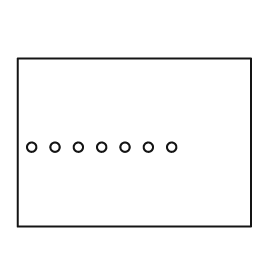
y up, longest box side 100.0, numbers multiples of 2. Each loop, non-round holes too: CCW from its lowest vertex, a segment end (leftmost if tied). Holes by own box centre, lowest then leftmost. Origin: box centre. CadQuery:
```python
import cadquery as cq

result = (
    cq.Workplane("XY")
    .moveTo(-50.0, -36.0)
    .lineTo(50.0, -36.0)
    .lineTo(50.0, 36.0)
    .lineTo(-50.0, 36.0)
    .close()
    .moveTo(-44.0, -2.0)
    .circle(2.0)
    .moveTo(-34.0, -2.0)
    .circle(2.0)
    .moveTo(-24.0, -2.0)
    .circle(2.0)
    .moveTo(-14.0, -2.0)
    .circle(2.0)
    .moveTo(-4.0, -2.0)
    .circle(2.0)
    .moveTo(6.0, -2.0)
    .circle(2.0)
    .moveTo(16.0, -2.0)
    .circle(2.0)
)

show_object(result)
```